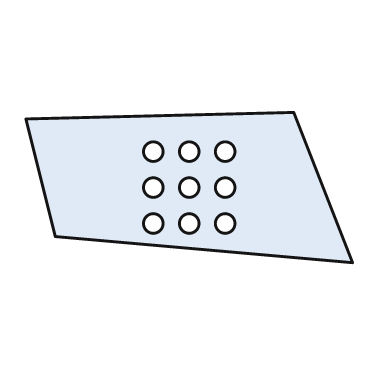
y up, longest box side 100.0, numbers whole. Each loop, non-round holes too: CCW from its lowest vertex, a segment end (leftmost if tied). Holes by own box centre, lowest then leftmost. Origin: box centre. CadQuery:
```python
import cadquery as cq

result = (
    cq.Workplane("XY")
    .moveTo(50.0, -23.0)
    .lineTo(32.0, 23.0)
    .lineTo(-50.0, 21.0)
    .lineTo(-41.0, -15.0)
    .close()
    .moveTo(-11.0, -11.0)
    .circle(3.0)
    .moveTo(0.0, -11.0)
    .circle(3.0)
    .moveTo(11.0, -11.0)
    .circle(3.0)
    .moveTo(-11.0, 0.0)
    .circle(3.0)
    .moveTo(0.0, 0.0)
    .circle(3.0)
    .moveTo(11.0, 0.0)
    .circle(3.0)
    .moveTo(-11.0, 11.0)
    .circle(3.0)
    .moveTo(0.0, 11.0)
    .circle(3.0)
    .moveTo(11.0, 11.0)
    .circle(3.0)
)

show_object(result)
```